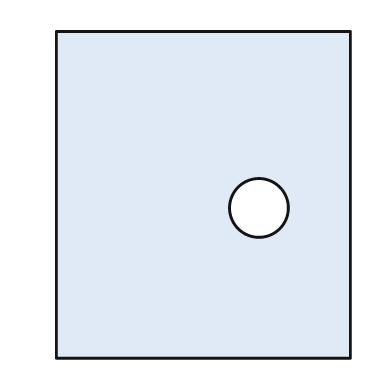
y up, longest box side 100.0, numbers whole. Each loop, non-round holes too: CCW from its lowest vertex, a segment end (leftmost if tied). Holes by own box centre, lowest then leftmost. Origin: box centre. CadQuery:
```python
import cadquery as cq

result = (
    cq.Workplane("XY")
    .moveTo(-45.0, -50.0)
    .lineTo(45.0, -50.0)
    .lineTo(45.0, 50.0)
    .lineTo(-45.0, 50.0)
    .close()
    .moveTo(17.0, -4.0)
    .circle(9.0)
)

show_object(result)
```